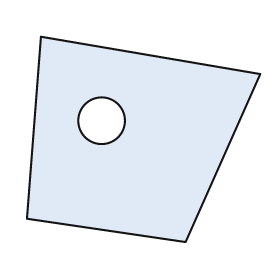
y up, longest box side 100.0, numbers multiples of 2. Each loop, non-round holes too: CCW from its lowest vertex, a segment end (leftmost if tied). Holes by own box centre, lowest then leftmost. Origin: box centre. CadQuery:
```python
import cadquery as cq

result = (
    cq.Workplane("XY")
    .moveTo(18.0, -44.0)
    .lineTo(50.0, 28.0)
    .lineTo(-44.0, 44.0)
    .lineTo(-50.0, -34.0)
    .close()
    .moveTo(-18.0, 8.0)
    .circle(10.0)
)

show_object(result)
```